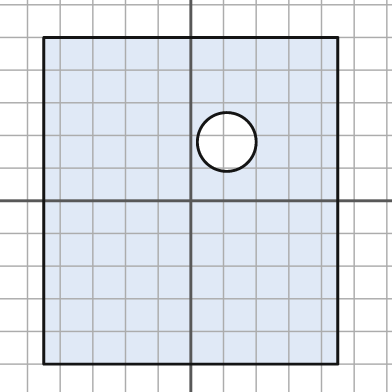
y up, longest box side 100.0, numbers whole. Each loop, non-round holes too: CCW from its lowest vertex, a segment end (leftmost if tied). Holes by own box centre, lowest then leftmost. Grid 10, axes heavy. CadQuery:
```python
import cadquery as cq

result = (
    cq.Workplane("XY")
    .moveTo(-45.0, -50.0)
    .lineTo(45.0, -50.0)
    .lineTo(45.0, 50.0)
    .lineTo(-45.0, 50.0)
    .close()
    .moveTo(11.0, 18.0)
    .circle(9.0)
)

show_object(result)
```